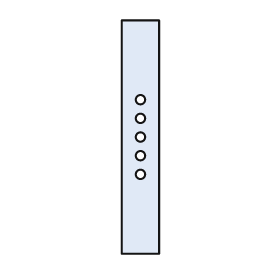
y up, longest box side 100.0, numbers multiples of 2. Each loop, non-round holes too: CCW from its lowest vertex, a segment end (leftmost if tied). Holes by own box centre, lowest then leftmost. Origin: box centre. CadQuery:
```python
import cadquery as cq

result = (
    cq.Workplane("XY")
    .moveTo(-8.0, -50.0)
    .lineTo(8.0, -50.0)
    .lineTo(8.0, 50.0)
    .lineTo(-8.0, 50.0)
    .close()
    .moveTo(0.0, -16.0)
    .circle(2.0)
    .moveTo(0.0, -8.0)
    .circle(2.0)
    .moveTo(0.0, 0.0)
    .circle(2.0)
    .moveTo(0.0, 8.0)
    .circle(2.0)
    .moveTo(0.0, 16.0)
    .circle(2.0)
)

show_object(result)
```